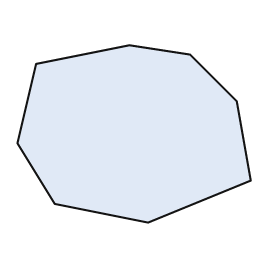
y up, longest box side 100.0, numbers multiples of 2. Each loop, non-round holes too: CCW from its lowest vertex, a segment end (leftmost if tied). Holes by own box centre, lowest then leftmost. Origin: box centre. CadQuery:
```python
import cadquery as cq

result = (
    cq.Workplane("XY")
    .moveTo(6.0, -38.0)
    .lineTo(50.0, -20.0)
    .lineTo(44.0, 14.0)
    .lineTo(24.0, 34.0)
    .lineTo(-2.0, 38.0)
    .lineTo(-42.0, 30.0)
    .lineTo(-50.0, -4.0)
    .lineTo(-34.0, -30.0)
    .close()
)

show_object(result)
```